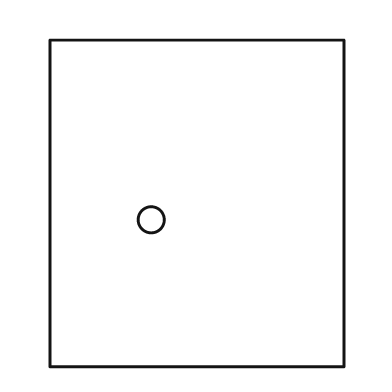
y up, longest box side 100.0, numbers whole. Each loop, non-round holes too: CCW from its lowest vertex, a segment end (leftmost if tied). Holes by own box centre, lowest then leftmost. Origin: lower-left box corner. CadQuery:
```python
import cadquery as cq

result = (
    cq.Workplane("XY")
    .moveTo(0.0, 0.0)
    .lineTo(90.0, 0.0)
    .lineTo(90.0, 100.0)
    .lineTo(0.0, 100.0)
    .close()
    .moveTo(31.0, 45.0)
    .circle(4.0)
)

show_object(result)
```